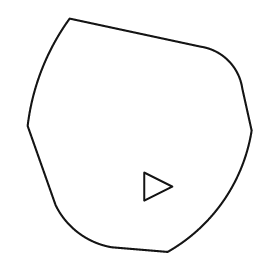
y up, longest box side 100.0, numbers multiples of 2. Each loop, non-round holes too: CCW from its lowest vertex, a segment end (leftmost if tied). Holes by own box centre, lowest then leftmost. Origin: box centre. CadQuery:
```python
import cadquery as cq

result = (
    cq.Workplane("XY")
    .moveTo(12.0, -50.0)
    .threePointArc((36.0, -28.0), (48.0, 2.0))
    .lineTo(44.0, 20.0)
    .threePointArc((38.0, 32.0), (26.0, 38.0))
    .lineTo(-30.0, 50.0)
    .threePointArc((-42.0, 28.0), (-48.0, 4.0))
    .lineTo(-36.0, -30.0)
    .threePointArc((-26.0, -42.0), (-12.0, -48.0))
    .close()
    .moveTo(2.0, -28.0)
    .lineTo(14.0, -22.0)
    .lineTo(2.0, -16.0)
    .close()
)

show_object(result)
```